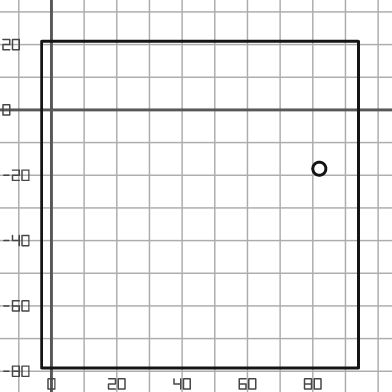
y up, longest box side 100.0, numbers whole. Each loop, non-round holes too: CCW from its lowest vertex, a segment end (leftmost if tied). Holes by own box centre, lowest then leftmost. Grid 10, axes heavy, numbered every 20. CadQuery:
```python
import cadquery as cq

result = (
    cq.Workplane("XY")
    .moveTo(-3.0, -79.0)
    .lineTo(94.0, -79.0)
    .lineTo(94.0, 21.0)
    .lineTo(-3.0, 21.0)
    .close()
    .moveTo(82.0, -18.0)
    .circle(2.0)
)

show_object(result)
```